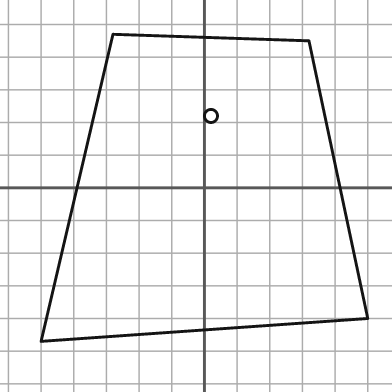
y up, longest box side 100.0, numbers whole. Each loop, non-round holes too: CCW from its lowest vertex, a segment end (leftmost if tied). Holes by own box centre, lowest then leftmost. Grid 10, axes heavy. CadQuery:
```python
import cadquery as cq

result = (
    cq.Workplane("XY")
    .moveTo(-50.0, -47.0)
    .lineTo(50.0, -40.0)
    .lineTo(32.0, 45.0)
    .lineTo(-28.0, 47.0)
    .close()
    .moveTo(2.0, 22.0)
    .circle(2.0)
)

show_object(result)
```